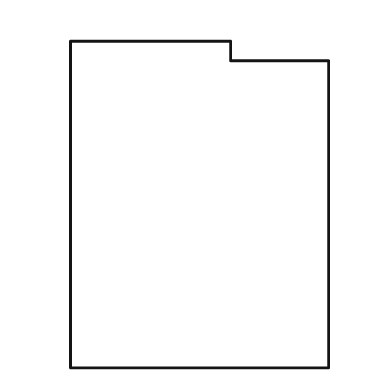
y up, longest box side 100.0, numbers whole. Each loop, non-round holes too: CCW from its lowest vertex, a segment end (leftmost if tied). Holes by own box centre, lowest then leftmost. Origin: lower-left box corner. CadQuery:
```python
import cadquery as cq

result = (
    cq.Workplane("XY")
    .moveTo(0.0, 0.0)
    .lineTo(79.0, 0.0)
    .lineTo(79.0, 94.0)
    .lineTo(49.0, 94.0)
    .lineTo(49.0, 100.0)
    .lineTo(0.0, 100.0)
    .close()
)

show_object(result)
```